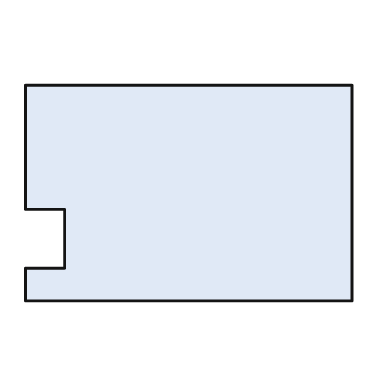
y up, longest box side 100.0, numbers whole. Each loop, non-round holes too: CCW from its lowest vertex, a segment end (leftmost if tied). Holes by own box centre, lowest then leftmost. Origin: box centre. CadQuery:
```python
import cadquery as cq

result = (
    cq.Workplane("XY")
    .moveTo(-50.0, -33.0)
    .lineTo(50.0, -33.0)
    .lineTo(50.0, 33.0)
    .lineTo(-50.0, 33.0)
    .lineTo(-50.0, -5.0)
    .lineTo(-38.0, -5.0)
    .lineTo(-38.0, -23.0)
    .lineTo(-50.0, -23.0)
    .close()
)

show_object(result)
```